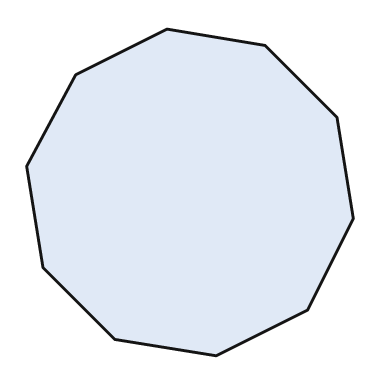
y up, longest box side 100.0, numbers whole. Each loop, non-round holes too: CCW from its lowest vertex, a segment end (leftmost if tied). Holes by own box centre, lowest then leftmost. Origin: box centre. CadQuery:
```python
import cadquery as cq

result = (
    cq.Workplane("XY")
    .moveTo(8.0, -50.0)
    .lineTo(36.0, -36.0)
    .lineTo(50.0, -8.0)
    .lineTo(45.0, 23.0)
    .lineTo(23.0, 45.0)
    .lineTo(-7.0, 50.0)
    .lineTo(-35.0, 36.0)
    .lineTo(-50.0, 8.0)
    .lineTo(-45.0, -23.0)
    .lineTo(-23.0, -45.0)
    .close()
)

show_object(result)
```